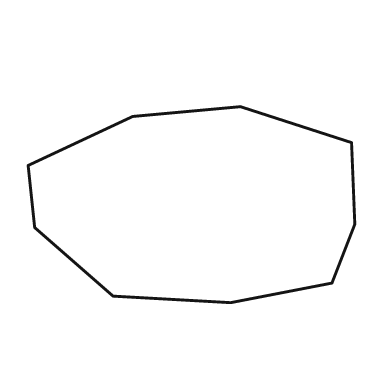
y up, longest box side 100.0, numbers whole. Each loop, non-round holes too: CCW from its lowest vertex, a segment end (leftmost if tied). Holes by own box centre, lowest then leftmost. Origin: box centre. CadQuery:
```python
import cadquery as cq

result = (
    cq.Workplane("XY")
    .moveTo(12.0, -30.0)
    .lineTo(43.0, -24.0)
    .lineTo(50.0, -6.0)
    .lineTo(49.0, 19.0)
    .lineTo(15.0, 30.0)
    .lineTo(-18.0, 27.0)
    .lineTo(-50.0, 12.0)
    .lineTo(-48.0, -7.0)
    .lineTo(-24.0, -28.0)
    .close()
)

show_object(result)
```